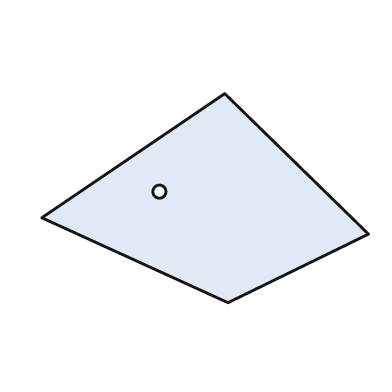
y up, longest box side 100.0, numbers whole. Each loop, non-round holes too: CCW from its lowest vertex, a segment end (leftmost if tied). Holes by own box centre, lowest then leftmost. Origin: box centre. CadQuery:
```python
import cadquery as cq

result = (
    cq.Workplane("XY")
    .moveTo(7.0, -32.0)
    .lineTo(50.0, -11.0)
    .lineTo(6.0, 32.0)
    .lineTo(-50.0, -6.0)
    .close()
    .moveTo(-14.0, 2.0)
    .circle(2.0)
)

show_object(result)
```